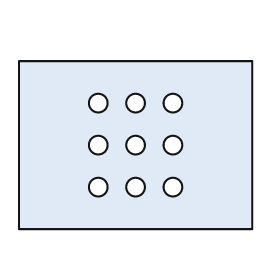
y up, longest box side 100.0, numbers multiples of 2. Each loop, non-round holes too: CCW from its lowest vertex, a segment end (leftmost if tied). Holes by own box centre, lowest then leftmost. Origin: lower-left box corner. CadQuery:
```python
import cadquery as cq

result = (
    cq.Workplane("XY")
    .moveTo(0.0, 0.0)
    .lineTo(100.0, 0.0)
    .lineTo(100.0, 72.0)
    .lineTo(0.0, 72.0)
    .close()
    .moveTo(34.0, 18.0)
    .circle(4.0)
    .moveTo(50.0, 18.0)
    .circle(4.0)
    .moveTo(66.0, 18.0)
    .circle(4.0)
    .moveTo(34.0, 36.0)
    .circle(4.0)
    .moveTo(50.0, 36.0)
    .circle(4.0)
    .moveTo(66.0, 36.0)
    .circle(4.0)
    .moveTo(34.0, 54.0)
    .circle(4.0)
    .moveTo(50.0, 54.0)
    .circle(4.0)
    .moveTo(66.0, 54.0)
    .circle(4.0)
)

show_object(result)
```